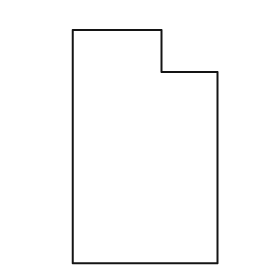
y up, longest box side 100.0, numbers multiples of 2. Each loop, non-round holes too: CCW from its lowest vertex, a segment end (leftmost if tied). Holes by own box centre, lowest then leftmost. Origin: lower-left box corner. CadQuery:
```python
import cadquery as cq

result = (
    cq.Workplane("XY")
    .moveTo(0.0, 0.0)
    .lineTo(62.0, 0.0)
    .lineTo(62.0, 82.0)
    .lineTo(38.0, 82.0)
    .lineTo(38.0, 100.0)
    .lineTo(0.0, 100.0)
    .close()
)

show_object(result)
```